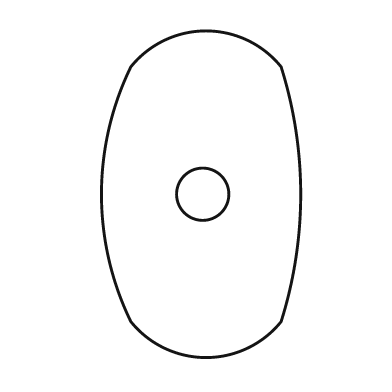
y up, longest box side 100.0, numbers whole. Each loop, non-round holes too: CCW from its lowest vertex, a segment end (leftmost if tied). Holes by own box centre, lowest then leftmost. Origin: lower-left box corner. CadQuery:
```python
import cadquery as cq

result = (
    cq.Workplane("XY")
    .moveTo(9.0, 11.0)
    .threePointArc((32.0, 0.0), (55.0, 11.0))
    .threePointArc((61.0, 50.0), (55.0, 89.0))
    .threePointArc((32.0, 100.0), (9.0, 89.0))
    .threePointArc((0.0, 50.0), (9.0, 11.0))
    .close()
    .moveTo(31.0, 50.0)
    .circle(8.0)
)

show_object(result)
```